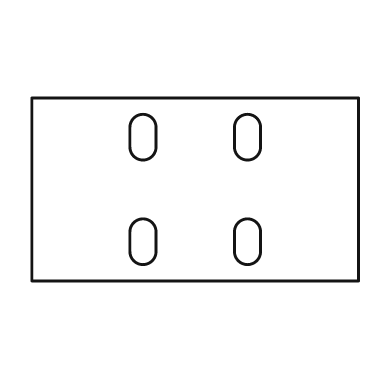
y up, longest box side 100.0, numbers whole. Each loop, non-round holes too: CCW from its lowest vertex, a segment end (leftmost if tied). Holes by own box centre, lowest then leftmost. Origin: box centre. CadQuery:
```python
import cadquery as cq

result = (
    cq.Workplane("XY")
    .moveTo(-50.0, -28.0)
    .lineTo(50.0, -28.0)
    .lineTo(50.0, 28.0)
    .lineTo(-50.0, 28.0)
    .close()
    .moveTo(-20.0, -19.0)
    .threePointArc((-16.0, -23.0), (-12.0, -19.0))
    .lineTo(-12.0, -13.0)
    .threePointArc((-16.0, -9.0), (-20.0, -13.0))
    .close()
    .moveTo(12.0, -19.0)
    .threePointArc((16.0, -23.0), (20.0, -19.0))
    .lineTo(20.0, -13.0)
    .threePointArc((16.0, -9.0), (12.0, -13.0))
    .close()
    .moveTo(-20.0, 13.0)
    .threePointArc((-16.0, 9.0), (-12.0, 13.0))
    .lineTo(-12.0, 19.0)
    .threePointArc((-16.0, 23.0), (-20.0, 19.0))
    .close()
    .moveTo(12.0, 13.0)
    .threePointArc((16.0, 9.0), (20.0, 13.0))
    .lineTo(20.0, 19.0)
    .threePointArc((16.0, 23.0), (12.0, 19.0))
    .close()
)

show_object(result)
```